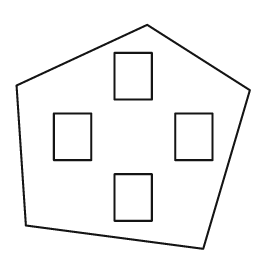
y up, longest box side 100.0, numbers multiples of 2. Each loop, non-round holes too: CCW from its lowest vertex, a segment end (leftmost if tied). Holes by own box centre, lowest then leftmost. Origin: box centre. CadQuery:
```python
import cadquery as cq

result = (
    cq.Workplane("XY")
    .moveTo(30.0, -48.0)
    .lineTo(50.0, 20.0)
    .lineTo(6.0, 48.0)
    .lineTo(-50.0, 22.0)
    .lineTo(-46.0, -38.0)
    .close()
    .moveTo(-8.0, -36.0)
    .lineTo(8.0, -36.0)
    .lineTo(8.0, -16.0)
    .lineTo(-8.0, -16.0)
    .close()
    .moveTo(-34.0, -10.0)
    .lineTo(-18.0, -10.0)
    .lineTo(-18.0, 10.0)
    .lineTo(-34.0, 10.0)
    .close()
    .moveTo(18.0, -10.0)
    .lineTo(34.0, -10.0)
    .lineTo(34.0, 10.0)
    .lineTo(18.0, 10.0)
    .close()
    .moveTo(-8.0, 16.0)
    .lineTo(8.0, 16.0)
    .lineTo(8.0, 36.0)
    .lineTo(-8.0, 36.0)
    .close()
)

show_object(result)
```